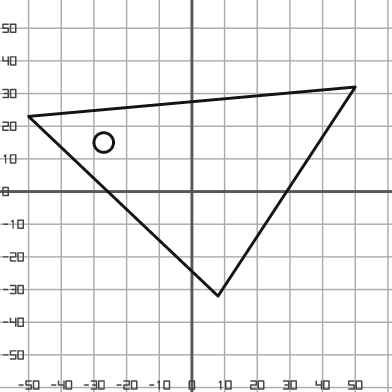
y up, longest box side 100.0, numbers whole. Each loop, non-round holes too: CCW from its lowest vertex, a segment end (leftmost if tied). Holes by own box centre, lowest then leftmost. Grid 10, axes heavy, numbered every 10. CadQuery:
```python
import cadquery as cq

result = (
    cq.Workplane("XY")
    .moveTo(8.0, -32.0)
    .lineTo(50.0, 32.0)
    .lineTo(-50.0, 23.0)
    .close()
    .moveTo(-27.0, 15.0)
    .circle(3.0)
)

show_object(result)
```